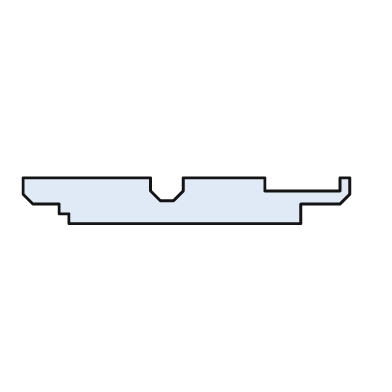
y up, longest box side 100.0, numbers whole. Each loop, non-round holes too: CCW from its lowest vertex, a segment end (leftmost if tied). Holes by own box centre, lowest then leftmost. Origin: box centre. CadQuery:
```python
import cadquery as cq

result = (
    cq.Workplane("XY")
    .moveTo(-36.0, -7.0)
    .lineTo(35.0, -7.0)
    .lineTo(35.0, -1.0)
    .lineTo(47.0, -1.0)
    .lineTo(50.0, 2.0)
    .lineTo(50.0, 7.0)
    .lineTo(47.0, 7.0)
    .lineTo(47.0, 3.0)
    .lineTo(24.0, 3.0)
    .lineTo(24.0, 7.0)
    .lineTo(-1.0, 7.0)
    .lineTo(-1.0, 3.0)
    .lineTo(-4.0, 0.0)
    .lineTo(-8.0, 0.0)
    .lineTo(-11.0, 3.0)
    .lineTo(-11.0, 7.0)
    .lineTo(-50.0, 7.0)
    .lineTo(-50.0, 2.0)
    .lineTo(-47.0, -1.0)
    .lineTo(-39.0, -1.0)
    .lineTo(-39.0, -4.0)
    .lineTo(-36.0, -4.0)
    .close()
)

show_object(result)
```